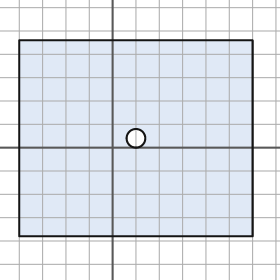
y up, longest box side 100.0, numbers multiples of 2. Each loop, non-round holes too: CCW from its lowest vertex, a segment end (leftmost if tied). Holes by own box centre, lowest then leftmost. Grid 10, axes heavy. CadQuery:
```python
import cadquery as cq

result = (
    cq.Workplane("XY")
    .moveTo(-40.0, -38.0)
    .lineTo(60.0, -38.0)
    .lineTo(60.0, 46.0)
    .lineTo(-40.0, 46.0)
    .close()
    .moveTo(10.0, 4.0)
    .circle(4.0)
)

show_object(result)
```